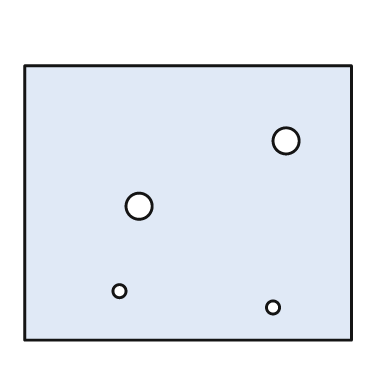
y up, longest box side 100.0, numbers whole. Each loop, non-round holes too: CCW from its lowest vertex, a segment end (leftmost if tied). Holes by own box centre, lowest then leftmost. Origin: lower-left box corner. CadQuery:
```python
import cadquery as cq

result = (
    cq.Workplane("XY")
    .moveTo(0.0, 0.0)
    .lineTo(100.0, 0.0)
    .lineTo(100.0, 84.0)
    .lineTo(0.0, 84.0)
    .close()
    .moveTo(76.0, 10.0)
    .circle(2.0)
    .moveTo(29.0, 15.0)
    .circle(2.0)
    .moveTo(35.0, 41.0)
    .circle(4.0)
    .moveTo(80.0, 61.0)
    .circle(4.0)
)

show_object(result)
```